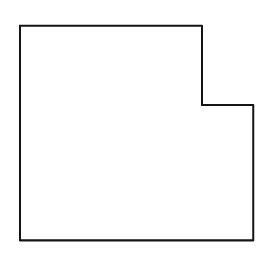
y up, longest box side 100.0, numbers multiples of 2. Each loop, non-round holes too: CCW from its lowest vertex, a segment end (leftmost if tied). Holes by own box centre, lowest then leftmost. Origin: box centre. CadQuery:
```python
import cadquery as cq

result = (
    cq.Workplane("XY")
    .moveTo(-50.0, -46.0)
    .lineTo(50.0, -46.0)
    .lineTo(50.0, 12.0)
    .lineTo(28.0, 12.0)
    .lineTo(28.0, 46.0)
    .lineTo(-50.0, 46.0)
    .close()
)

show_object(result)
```